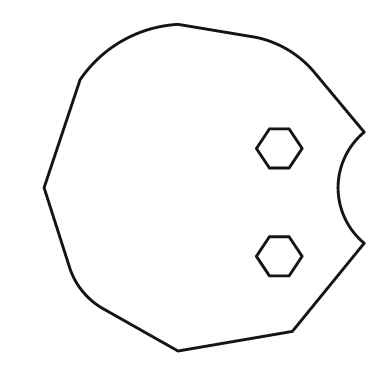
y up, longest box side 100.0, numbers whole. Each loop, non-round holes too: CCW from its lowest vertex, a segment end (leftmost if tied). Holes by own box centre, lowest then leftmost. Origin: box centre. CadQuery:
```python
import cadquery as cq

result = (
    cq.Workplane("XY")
    .moveTo(-8.0, -50.0)
    .lineTo(27.0, -44.0)
    .lineTo(49.0, -17.0)
    .threePointArc((41.0, 0.0), (49.0, 17.0))
    .lineTo(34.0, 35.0)
    .threePointArc((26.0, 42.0), (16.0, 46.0))
    .lineTo(-8.0, 50.0)
    .threePointArc((-25.0, 45.0), (-38.0, 33.0))
    .lineTo(-49.0, 0.0)
    .lineTo(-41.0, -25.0)
    .threePointArc((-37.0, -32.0), (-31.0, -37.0))
    .close()
    .moveTo(20.0, -27.0)
    .lineTo(26.0, -27.0)
    .lineTo(30.0, -21.0)
    .lineTo(26.0, -15.0)
    .lineTo(20.0, -15.0)
    .lineTo(16.0, -21.0)
    .close()
    .moveTo(20.0, 6.0)
    .lineTo(26.0, 6.0)
    .lineTo(30.0, 12.0)
    .lineTo(26.0, 18.0)
    .lineTo(20.0, 18.0)
    .lineTo(16.0, 12.0)
    .close()
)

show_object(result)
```